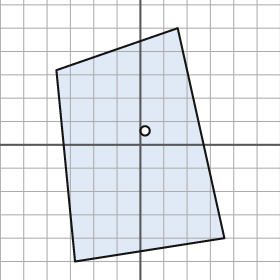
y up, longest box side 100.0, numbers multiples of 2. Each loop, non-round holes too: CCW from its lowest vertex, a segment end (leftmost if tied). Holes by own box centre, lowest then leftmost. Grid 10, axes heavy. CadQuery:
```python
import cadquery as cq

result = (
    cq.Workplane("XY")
    .moveTo(-28.0, -50.0)
    .lineTo(36.0, -40.0)
    .lineTo(16.0, 50.0)
    .lineTo(-36.0, 32.0)
    .close()
    .moveTo(2.0, 6.0)
    .circle(2.0)
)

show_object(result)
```